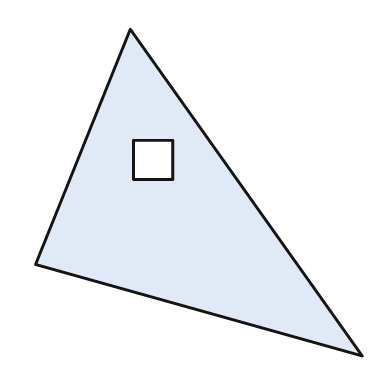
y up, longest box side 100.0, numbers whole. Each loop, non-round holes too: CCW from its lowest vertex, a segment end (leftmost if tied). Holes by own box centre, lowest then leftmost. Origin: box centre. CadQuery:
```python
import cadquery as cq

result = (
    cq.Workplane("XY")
    .moveTo(50.0, -50.0)
    .lineTo(-21.0, 50.0)
    .lineTo(-50.0, -22.0)
    .close()
    .moveTo(-20.0, 4.0)
    .lineTo(-8.0, 4.0)
    .lineTo(-8.0, 16.0)
    .lineTo(-20.0, 16.0)
    .close()
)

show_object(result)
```